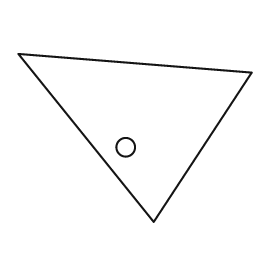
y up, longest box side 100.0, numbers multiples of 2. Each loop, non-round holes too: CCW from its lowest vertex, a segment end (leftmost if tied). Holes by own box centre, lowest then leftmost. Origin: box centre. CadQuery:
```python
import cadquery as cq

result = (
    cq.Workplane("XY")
    .moveTo(8.0, -36.0)
    .lineTo(50.0, 28.0)
    .lineTo(-50.0, 36.0)
    .close()
    .moveTo(-4.0, -4.0)
    .circle(4.0)
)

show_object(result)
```